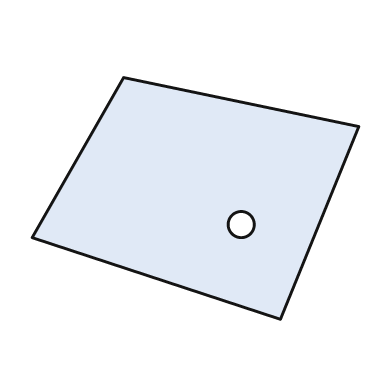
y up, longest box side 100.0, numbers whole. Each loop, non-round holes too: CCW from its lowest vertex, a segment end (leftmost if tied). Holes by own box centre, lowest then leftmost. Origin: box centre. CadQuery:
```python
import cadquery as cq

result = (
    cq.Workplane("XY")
    .moveTo(26.0, -37.0)
    .lineTo(50.0, 22.0)
    .lineTo(-22.0, 37.0)
    .lineTo(-50.0, -12.0)
    .close()
    .moveTo(14.0, -8.0)
    .circle(4.0)
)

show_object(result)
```